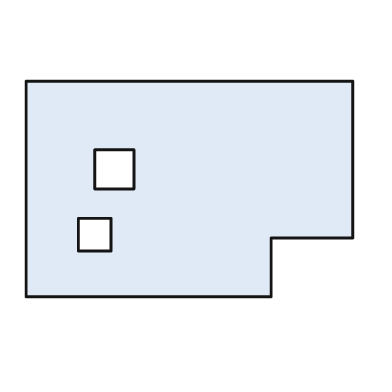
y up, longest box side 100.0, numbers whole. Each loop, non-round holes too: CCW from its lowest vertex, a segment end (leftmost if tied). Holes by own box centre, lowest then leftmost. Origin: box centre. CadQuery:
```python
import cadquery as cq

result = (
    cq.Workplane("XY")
    .moveTo(-50.0, -33.0)
    .lineTo(25.0, -33.0)
    .lineTo(25.0, -15.0)
    .lineTo(50.0, -15.0)
    .lineTo(50.0, 33.0)
    .lineTo(-50.0, 33.0)
    .close()
    .moveTo(-34.0, -19.0)
    .lineTo(-24.0, -19.0)
    .lineTo(-24.0, -9.0)
    .lineTo(-34.0, -9.0)
    .close()
    .moveTo(-29.0, 0.0)
    .lineTo(-17.0, 0.0)
    .lineTo(-17.0, 12.0)
    .lineTo(-29.0, 12.0)
    .close()
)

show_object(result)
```